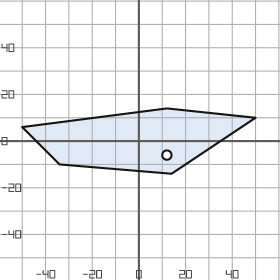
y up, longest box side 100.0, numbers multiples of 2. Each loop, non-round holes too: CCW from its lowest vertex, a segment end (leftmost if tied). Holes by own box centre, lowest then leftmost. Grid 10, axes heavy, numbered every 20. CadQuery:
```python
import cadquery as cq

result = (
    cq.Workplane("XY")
    .moveTo(14.0, -14.0)
    .lineTo(50.0, 10.0)
    .lineTo(12.0, 14.0)
    .lineTo(-50.0, 6.0)
    .lineTo(-34.0, -10.0)
    .close()
    .moveTo(12.0, -6.0)
    .circle(2.0)
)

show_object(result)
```